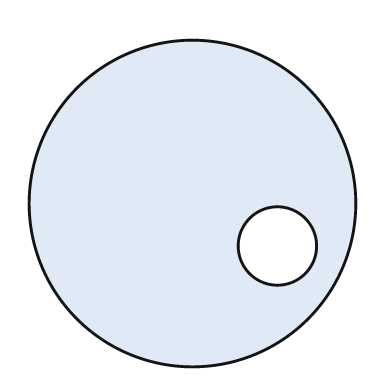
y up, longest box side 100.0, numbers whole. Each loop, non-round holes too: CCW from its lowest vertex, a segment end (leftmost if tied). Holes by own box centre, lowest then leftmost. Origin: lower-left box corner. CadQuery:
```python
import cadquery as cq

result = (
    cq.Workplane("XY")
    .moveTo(50.0, 50.0)
    .circle(50.0)
    .moveTo(76.0, 37.0)
    .circle(12.0)
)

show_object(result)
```